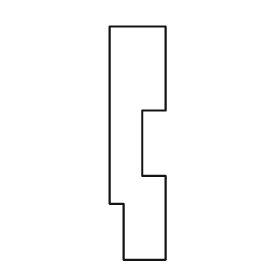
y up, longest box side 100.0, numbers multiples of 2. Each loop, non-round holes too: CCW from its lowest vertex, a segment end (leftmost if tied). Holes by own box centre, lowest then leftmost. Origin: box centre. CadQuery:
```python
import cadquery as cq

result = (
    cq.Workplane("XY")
    .moveTo(-6.0, -50.0)
    .lineTo(12.0, -50.0)
    .lineTo(12.0, -14.0)
    .lineTo(2.0, -14.0)
    .lineTo(2.0, 14.0)
    .lineTo(12.0, 14.0)
    .lineTo(12.0, 50.0)
    .lineTo(-12.0, 50.0)
    .lineTo(-12.0, -26.0)
    .lineTo(-6.0, -26.0)
    .close()
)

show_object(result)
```